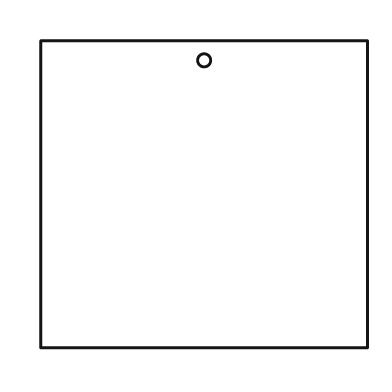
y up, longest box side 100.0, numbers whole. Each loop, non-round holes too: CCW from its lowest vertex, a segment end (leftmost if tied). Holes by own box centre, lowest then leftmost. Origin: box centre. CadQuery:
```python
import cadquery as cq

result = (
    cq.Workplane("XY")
    .moveTo(-50.0, -47.0)
    .lineTo(50.0, -47.0)
    .lineTo(50.0, 47.0)
    .lineTo(-50.0, 47.0)
    .close()
    .moveTo(0.0, 41.0)
    .circle(2.0)
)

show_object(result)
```